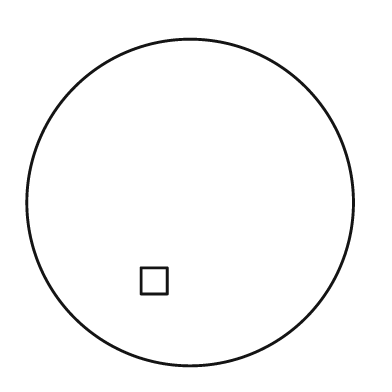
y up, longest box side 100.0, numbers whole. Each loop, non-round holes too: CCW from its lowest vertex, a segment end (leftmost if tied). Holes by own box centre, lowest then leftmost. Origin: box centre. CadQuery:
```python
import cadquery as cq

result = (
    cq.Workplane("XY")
    .moveTo(0.0, 0.0)
    .circle(50.0)
    .moveTo(-15.0, -28.0)
    .lineTo(-7.0, -28.0)
    .lineTo(-7.0, -20.0)
    .lineTo(-15.0, -20.0)
    .close()
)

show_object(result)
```